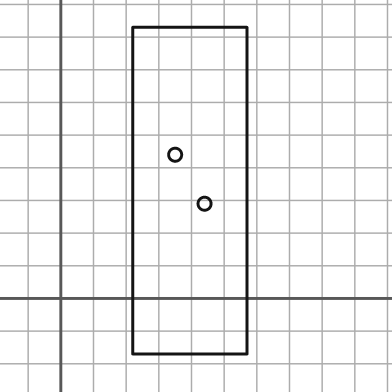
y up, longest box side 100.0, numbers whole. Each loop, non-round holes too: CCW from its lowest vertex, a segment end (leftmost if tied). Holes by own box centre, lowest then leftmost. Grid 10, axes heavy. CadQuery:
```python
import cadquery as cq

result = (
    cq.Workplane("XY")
    .moveTo(22.0, -17.0)
    .lineTo(57.0, -17.0)
    .lineTo(57.0, 83.0)
    .lineTo(22.0, 83.0)
    .close()
    .moveTo(44.0, 29.0)
    .circle(2.0)
    .moveTo(35.0, 44.0)
    .circle(2.0)
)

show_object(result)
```